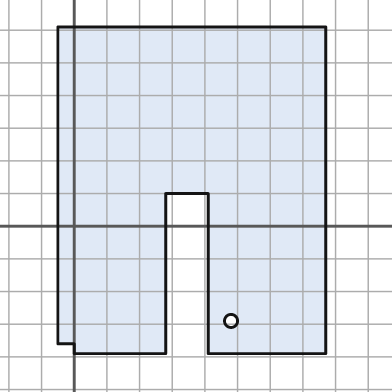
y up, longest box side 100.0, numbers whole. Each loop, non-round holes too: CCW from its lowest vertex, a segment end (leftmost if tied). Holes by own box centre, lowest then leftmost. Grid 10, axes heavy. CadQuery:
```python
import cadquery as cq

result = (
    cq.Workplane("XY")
    .moveTo(0.0, -39.0)
    .lineTo(28.0, -39.0)
    .lineTo(28.0, 10.0)
    .lineTo(41.0, 10.0)
    .lineTo(41.0, -39.0)
    .lineTo(77.0, -39.0)
    .lineTo(77.0, 61.0)
    .lineTo(-5.0, 61.0)
    .lineTo(-5.0, -36.0)
    .lineTo(0.0, -36.0)
    .close()
    .moveTo(48.0, -29.0)
    .circle(2.0)
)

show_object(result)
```